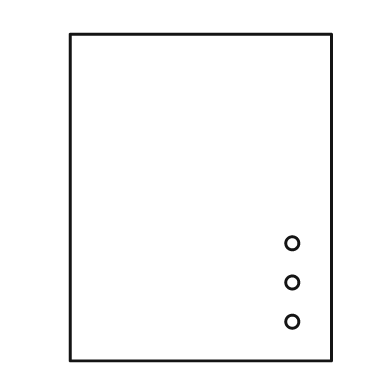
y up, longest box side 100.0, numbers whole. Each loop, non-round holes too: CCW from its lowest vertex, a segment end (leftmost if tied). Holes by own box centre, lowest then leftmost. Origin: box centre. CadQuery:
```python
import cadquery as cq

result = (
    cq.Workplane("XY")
    .moveTo(-40.0, -50.0)
    .lineTo(40.0, -50.0)
    .lineTo(40.0, 50.0)
    .lineTo(-40.0, 50.0)
    .close()
    .moveTo(28.0, -38.0)
    .circle(2.0)
    .moveTo(28.0, -26.0)
    .circle(2.0)
    .moveTo(28.0, -14.0)
    .circle(2.0)
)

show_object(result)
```